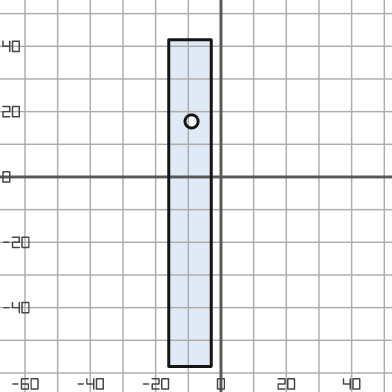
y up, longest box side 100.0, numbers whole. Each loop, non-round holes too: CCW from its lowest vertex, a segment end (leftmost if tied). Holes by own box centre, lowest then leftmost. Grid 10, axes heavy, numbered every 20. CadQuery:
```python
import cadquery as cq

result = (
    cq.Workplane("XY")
    .moveTo(-16.0, -58.0)
    .lineTo(-3.0, -58.0)
    .lineTo(-3.0, 42.0)
    .lineTo(-16.0, 42.0)
    .close()
    .moveTo(-9.0, 17.0)
    .circle(2.0)
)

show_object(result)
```